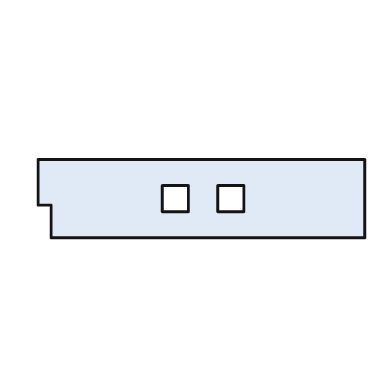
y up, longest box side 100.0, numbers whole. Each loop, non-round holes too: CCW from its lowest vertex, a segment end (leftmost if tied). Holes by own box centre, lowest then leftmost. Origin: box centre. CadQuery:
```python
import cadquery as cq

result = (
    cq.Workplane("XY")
    .moveTo(-46.0, -12.0)
    .lineTo(50.0, -12.0)
    .lineTo(50.0, 12.0)
    .lineTo(-50.0, 12.0)
    .lineTo(-50.0, -2.0)
    .lineTo(-46.0, -2.0)
    .close()
    .moveTo(-12.0, -4.0)
    .lineTo(-4.0, -4.0)
    .lineTo(-4.0, 4.0)
    .lineTo(-12.0, 4.0)
    .close()
    .moveTo(5.0, -4.0)
    .lineTo(13.0, -4.0)
    .lineTo(13.0, 4.0)
    .lineTo(5.0, 4.0)
    .close()
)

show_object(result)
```